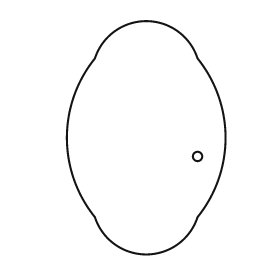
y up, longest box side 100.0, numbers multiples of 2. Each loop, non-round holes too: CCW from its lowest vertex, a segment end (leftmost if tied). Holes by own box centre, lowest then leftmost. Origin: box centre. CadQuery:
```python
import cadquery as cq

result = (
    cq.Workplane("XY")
    .moveTo(-22.0, -34.0)
    .threePointArc((0.0, -50.0), (22.0, -34.0))
    .threePointArc((34.0, 0.0), (22.0, 34.0))
    .threePointArc((0.0, 50.0), (-22.0, 34.0))
    .threePointArc((-34.0, 0.0), (-22.0, -34.0))
    .close()
    .moveTo(22.0, -8.0)
    .circle(2.0)
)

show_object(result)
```